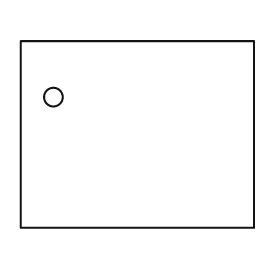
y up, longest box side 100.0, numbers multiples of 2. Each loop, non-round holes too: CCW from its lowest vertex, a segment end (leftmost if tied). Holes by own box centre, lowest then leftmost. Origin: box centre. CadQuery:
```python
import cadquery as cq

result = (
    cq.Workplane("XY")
    .moveTo(-50.0, -40.0)
    .lineTo(50.0, -40.0)
    .lineTo(50.0, 40.0)
    .lineTo(-50.0, 40.0)
    .close()
    .moveTo(-36.0, 16.0)
    .circle(4.0)
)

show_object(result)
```